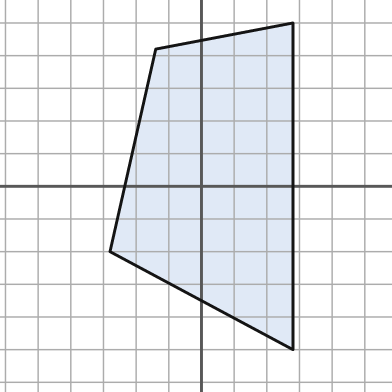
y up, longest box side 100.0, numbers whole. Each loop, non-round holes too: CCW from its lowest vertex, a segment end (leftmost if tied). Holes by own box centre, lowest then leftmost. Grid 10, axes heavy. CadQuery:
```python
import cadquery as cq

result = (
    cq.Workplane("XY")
    .moveTo(28.0, -50.0)
    .lineTo(28.0, 50.0)
    .lineTo(-14.0, 42.0)
    .lineTo(-28.0, -20.0)
    .close()
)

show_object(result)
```